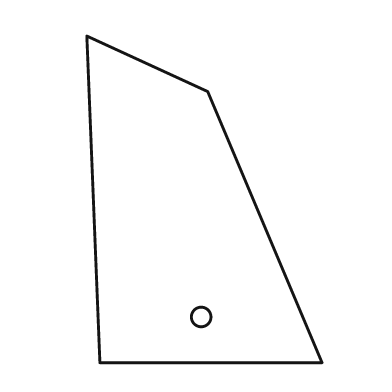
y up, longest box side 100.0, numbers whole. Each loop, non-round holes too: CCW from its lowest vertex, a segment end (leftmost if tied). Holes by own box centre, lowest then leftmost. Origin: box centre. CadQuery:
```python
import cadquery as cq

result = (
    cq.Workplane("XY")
    .moveTo(-32.0, -50.0)
    .lineTo(36.0, -50.0)
    .lineTo(1.0, 33.0)
    .lineTo(-36.0, 50.0)
    .close()
    .moveTo(-1.0, -36.0)
    .circle(3.0)
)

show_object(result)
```